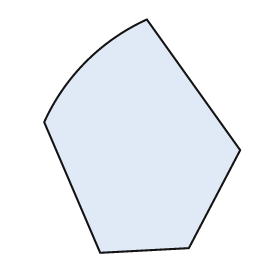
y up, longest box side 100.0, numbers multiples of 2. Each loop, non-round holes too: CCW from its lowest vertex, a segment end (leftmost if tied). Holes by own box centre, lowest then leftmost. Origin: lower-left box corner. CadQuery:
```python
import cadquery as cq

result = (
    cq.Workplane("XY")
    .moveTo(24.0, 0.0)
    .lineTo(62.0, 2.0)
    .lineTo(84.0, 44.0)
    .lineTo(44.0, 100.0)
    .threePointArc((18.0, 82.0), (0.0, 56.0))
    .close()
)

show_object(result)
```